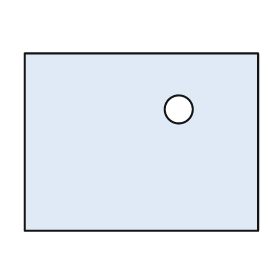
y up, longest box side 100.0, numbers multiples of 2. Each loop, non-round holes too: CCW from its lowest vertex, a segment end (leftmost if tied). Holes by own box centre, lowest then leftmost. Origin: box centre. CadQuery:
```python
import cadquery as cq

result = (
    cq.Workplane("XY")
    .moveTo(-50.0, -38.0)
    .lineTo(50.0, -38.0)
    .lineTo(50.0, 38.0)
    .lineTo(-50.0, 38.0)
    .close()
    .moveTo(16.0, 14.0)
    .circle(6.0)
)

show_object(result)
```